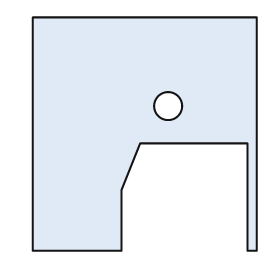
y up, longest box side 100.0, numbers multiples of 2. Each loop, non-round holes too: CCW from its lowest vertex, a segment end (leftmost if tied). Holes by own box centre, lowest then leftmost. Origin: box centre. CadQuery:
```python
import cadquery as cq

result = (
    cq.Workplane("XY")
    .moveTo(-48.0, -50.0)
    .lineTo(-10.0, -50.0)
    .lineTo(-10.0, -24.0)
    .lineTo(-2.0, -4.0)
    .lineTo(44.0, -4.0)
    .lineTo(44.0, -50.0)
    .lineTo(48.0, -50.0)
    .lineTo(48.0, 50.0)
    .lineTo(-48.0, 50.0)
    .close()
    .moveTo(10.0, 12.0)
    .circle(6.0)
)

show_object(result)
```